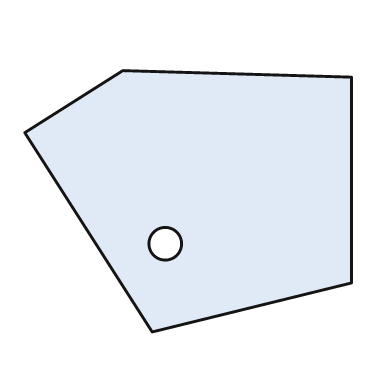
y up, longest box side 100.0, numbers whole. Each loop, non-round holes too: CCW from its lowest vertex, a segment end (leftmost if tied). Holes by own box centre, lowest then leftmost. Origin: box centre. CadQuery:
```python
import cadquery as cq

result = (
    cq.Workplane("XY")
    .moveTo(-11.0, -40.0)
    .lineTo(50.0, -25.0)
    .lineTo(50.0, 38.0)
    .lineTo(-20.0, 40.0)
    .lineTo(-50.0, 21.0)
    .close()
    .moveTo(-7.0, -13.0)
    .circle(5.0)
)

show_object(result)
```